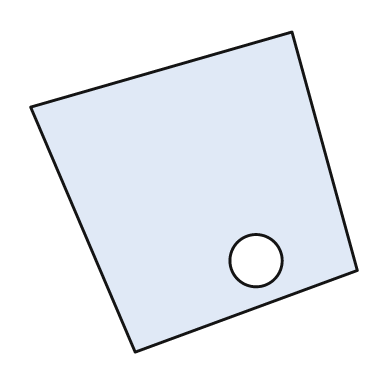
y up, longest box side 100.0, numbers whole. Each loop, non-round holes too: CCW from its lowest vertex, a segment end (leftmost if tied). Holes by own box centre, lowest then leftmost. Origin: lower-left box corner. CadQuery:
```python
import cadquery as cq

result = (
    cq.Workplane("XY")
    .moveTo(32.0, 0.0)
    .lineTo(100.0, 25.0)
    .lineTo(80.0, 98.0)
    .lineTo(0.0, 75.0)
    .close()
    .moveTo(69.0, 28.0)
    .circle(8.0)
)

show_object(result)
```